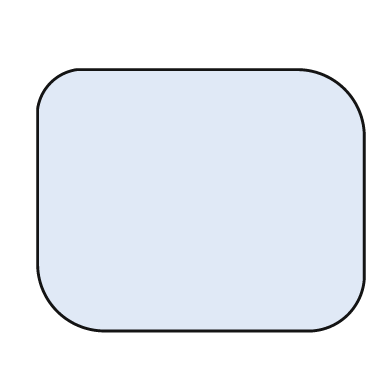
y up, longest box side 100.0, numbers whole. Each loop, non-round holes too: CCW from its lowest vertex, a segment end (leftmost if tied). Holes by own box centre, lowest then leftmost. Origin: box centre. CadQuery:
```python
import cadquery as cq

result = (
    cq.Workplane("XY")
    .moveTo(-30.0, -40.0)
    .lineTo(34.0, -40.0)
    .threePointArc((45.0, -35.0), (50.0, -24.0))
    .lineTo(50.0, 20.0)
    .threePointArc((44.0, 34.0), (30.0, 40.0))
    .lineTo(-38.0, 40.0)
    .threePointArc((-46.0, 36.0), (-50.0, 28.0))
    .lineTo(-50.0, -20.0)
    .threePointArc((-44.0, -34.0), (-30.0, -40.0))
    .close()
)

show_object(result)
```